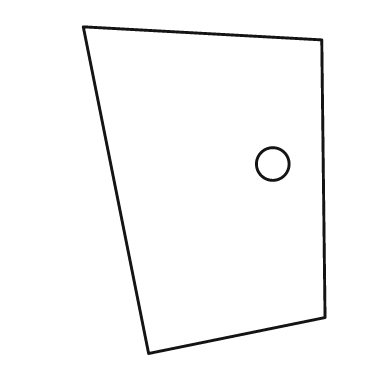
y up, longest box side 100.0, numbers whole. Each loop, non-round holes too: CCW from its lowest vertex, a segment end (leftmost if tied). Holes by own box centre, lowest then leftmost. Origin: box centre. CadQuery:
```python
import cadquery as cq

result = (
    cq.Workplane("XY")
    .moveTo(-17.0, -50.0)
    .lineTo(37.0, -39.0)
    .lineTo(36.0, 46.0)
    .lineTo(-37.0, 50.0)
    .close()
    .moveTo(21.0, 8.0)
    .circle(5.0)
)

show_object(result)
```